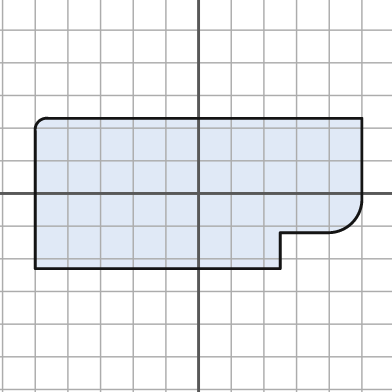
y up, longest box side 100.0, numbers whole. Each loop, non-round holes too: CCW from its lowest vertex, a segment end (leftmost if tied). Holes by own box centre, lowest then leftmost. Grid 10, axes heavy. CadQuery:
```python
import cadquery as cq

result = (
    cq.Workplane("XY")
    .moveTo(-50.0, -23.0)
    .lineTo(25.0, -23.0)
    .lineTo(25.0, -12.0)
    .lineTo(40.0, -12.0)
    .threePointArc((47.0, -9.0), (50.0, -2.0))
    .lineTo(50.0, 23.0)
    .lineTo(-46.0, 23.0)
    .threePointArc((-49.0, 22.0), (-50.0, 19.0))
    .close()
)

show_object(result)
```